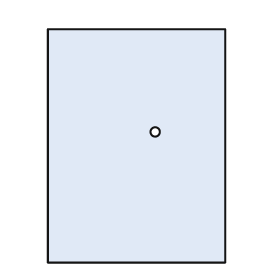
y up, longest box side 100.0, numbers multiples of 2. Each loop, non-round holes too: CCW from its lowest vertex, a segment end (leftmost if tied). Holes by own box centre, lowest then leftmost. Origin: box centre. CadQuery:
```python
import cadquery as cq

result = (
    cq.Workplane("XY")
    .moveTo(-38.0, -50.0)
    .lineTo(38.0, -50.0)
    .lineTo(38.0, 50.0)
    .lineTo(-38.0, 50.0)
    .close()
    .moveTo(8.0, 6.0)
    .circle(2.0)
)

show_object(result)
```